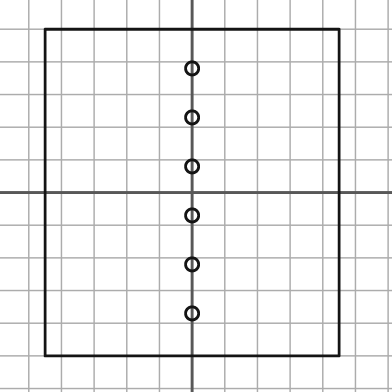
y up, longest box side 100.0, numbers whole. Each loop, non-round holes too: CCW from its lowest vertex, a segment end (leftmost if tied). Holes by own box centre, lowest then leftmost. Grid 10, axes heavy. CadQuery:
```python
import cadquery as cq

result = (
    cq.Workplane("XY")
    .moveTo(-45.0, -50.0)
    .lineTo(45.0, -50.0)
    .lineTo(45.0, 50.0)
    .lineTo(-45.0, 50.0)
    .close()
    .moveTo(0.0, -37.0)
    .circle(2.0)
    .moveTo(0.0, -22.0)
    .circle(2.0)
    .moveTo(0.0, -7.0)
    .circle(2.0)
    .moveTo(0.0, 8.0)
    .circle(2.0)
    .moveTo(0.0, 23.0)
    .circle(2.0)
    .moveTo(0.0, 38.0)
    .circle(2.0)
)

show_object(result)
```